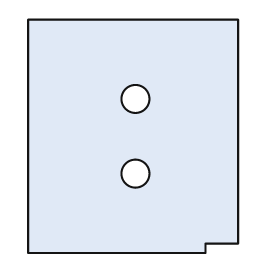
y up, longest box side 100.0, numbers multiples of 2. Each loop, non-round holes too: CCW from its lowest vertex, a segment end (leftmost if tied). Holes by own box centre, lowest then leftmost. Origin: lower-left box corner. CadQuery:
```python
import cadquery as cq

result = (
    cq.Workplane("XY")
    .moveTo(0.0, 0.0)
    .lineTo(76.0, 0.0)
    .lineTo(76.0, 4.0)
    .lineTo(90.0, 4.0)
    .lineTo(90.0, 100.0)
    .lineTo(0.0, 100.0)
    .close()
    .moveTo(46.0, 34.0)
    .circle(6.0)
    .moveTo(46.0, 66.0)
    .circle(6.0)
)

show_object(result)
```